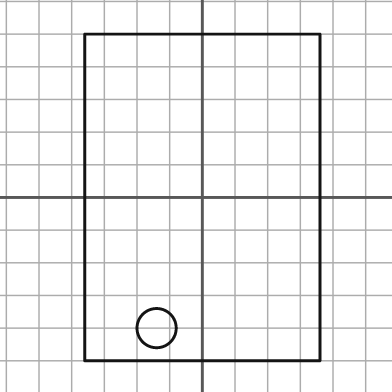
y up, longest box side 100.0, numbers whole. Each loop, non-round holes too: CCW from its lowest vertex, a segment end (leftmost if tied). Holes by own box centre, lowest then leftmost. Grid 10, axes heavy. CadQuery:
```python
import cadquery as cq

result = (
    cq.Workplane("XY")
    .moveTo(-36.0, -50.0)
    .lineTo(36.0, -50.0)
    .lineTo(36.0, 50.0)
    .lineTo(-36.0, 50.0)
    .close()
    .moveTo(-14.0, -40.0)
    .circle(6.0)
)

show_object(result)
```